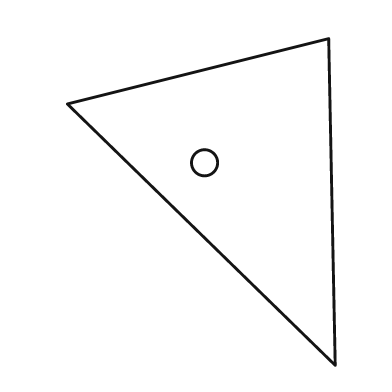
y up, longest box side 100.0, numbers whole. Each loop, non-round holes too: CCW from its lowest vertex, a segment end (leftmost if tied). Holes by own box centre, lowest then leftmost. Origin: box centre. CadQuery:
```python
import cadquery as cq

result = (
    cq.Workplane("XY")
    .moveTo(41.0, -50.0)
    .lineTo(39.0, 50.0)
    .lineTo(-41.0, 30.0)
    .close()
    .moveTo(1.0, 12.0)
    .circle(4.0)
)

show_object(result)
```